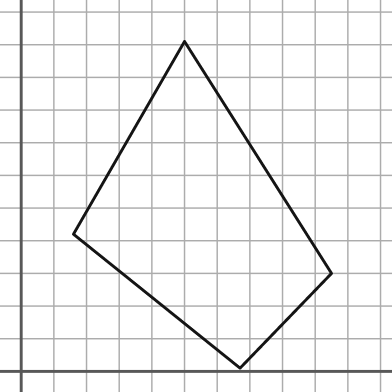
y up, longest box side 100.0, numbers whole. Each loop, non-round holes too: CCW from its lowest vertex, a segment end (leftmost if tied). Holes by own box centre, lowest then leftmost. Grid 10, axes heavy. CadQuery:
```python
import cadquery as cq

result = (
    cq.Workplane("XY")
    .moveTo(67.0, 1.0)
    .lineTo(95.0, 30.0)
    .lineTo(50.0, 101.0)
    .lineTo(16.0, 42.0)
    .close()
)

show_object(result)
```